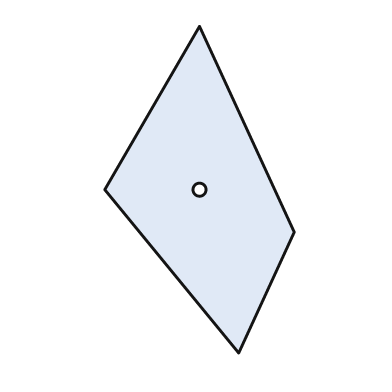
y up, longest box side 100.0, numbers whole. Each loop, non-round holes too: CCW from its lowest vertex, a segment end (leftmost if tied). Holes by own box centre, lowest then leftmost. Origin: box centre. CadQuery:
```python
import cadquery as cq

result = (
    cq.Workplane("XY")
    .moveTo(12.0, -50.0)
    .lineTo(29.0, -13.0)
    .lineTo(0.0, 50.0)
    .lineTo(-29.0, 0.0)
    .close()
    .moveTo(0.0, 0.0)
    .circle(2.0)
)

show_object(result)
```